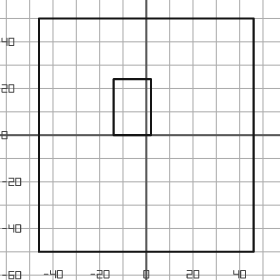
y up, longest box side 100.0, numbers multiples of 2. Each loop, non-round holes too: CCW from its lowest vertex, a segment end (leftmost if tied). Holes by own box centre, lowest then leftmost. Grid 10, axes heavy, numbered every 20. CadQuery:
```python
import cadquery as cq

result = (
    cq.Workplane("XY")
    .moveTo(-46.0, -50.0)
    .lineTo(46.0, -50.0)
    .lineTo(46.0, 50.0)
    .lineTo(-46.0, 50.0)
    .close()
    .moveTo(-14.0, 0.0)
    .lineTo(2.0, 0.0)
    .lineTo(2.0, 24.0)
    .lineTo(-14.0, 24.0)
    .close()
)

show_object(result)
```